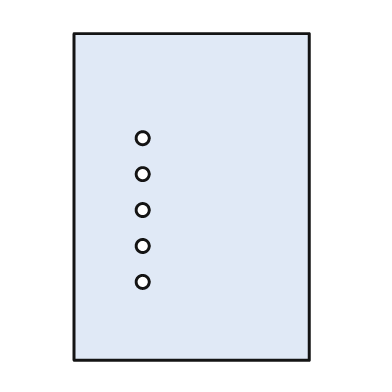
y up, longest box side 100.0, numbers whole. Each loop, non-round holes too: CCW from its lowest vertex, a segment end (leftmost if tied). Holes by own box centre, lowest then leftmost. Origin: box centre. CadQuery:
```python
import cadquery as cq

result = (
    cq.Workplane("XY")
    .moveTo(-36.0, -50.0)
    .lineTo(36.0, -50.0)
    .lineTo(36.0, 50.0)
    .lineTo(-36.0, 50.0)
    .close()
    .moveTo(-15.0, -26.0)
    .circle(2.0)
    .moveTo(-15.0, -15.0)
    .circle(2.0)
    .moveTo(-15.0, -4.0)
    .circle(2.0)
    .moveTo(-15.0, 7.0)
    .circle(2.0)
    .moveTo(-15.0, 18.0)
    .circle(2.0)
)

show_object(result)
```